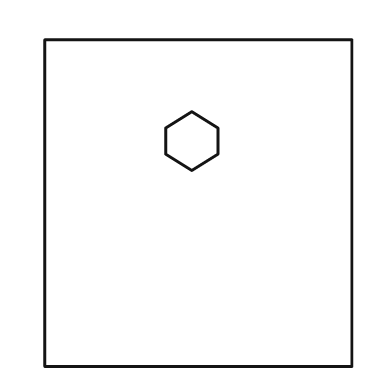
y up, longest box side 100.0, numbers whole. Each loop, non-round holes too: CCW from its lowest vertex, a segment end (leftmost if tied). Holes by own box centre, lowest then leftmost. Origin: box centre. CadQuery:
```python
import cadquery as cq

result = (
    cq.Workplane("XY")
    .moveTo(-47.0, -50.0)
    .lineTo(47.0, -50.0)
    .lineTo(47.0, 50.0)
    .lineTo(-47.0, 50.0)
    .close()
    .moveTo(-2.0, 10.0)
    .lineTo(6.0, 15.0)
    .lineTo(6.0, 23.0)
    .lineTo(-2.0, 28.0)
    .lineTo(-10.0, 23.0)
    .lineTo(-10.0, 15.0)
    .close()
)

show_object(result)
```